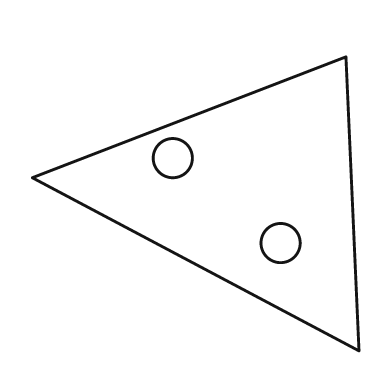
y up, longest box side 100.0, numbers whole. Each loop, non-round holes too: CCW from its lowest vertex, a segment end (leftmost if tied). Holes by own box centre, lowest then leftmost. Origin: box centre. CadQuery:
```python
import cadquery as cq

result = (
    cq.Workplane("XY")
    .moveTo(50.0, -45.0)
    .lineTo(46.0, 45.0)
    .lineTo(-50.0, 8.0)
    .close()
    .moveTo(26.0, -12.0)
    .circle(6.0)
    .moveTo(-7.0, 14.0)
    .circle(6.0)
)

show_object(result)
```